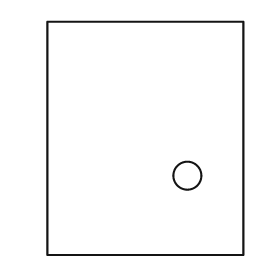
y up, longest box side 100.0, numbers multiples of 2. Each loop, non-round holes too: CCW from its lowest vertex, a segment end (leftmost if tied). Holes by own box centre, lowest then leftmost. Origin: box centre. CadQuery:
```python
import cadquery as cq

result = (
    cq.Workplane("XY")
    .moveTo(-42.0, -50.0)
    .lineTo(42.0, -50.0)
    .lineTo(42.0, 50.0)
    .lineTo(-42.0, 50.0)
    .close()
    .moveTo(18.0, -16.0)
    .circle(6.0)
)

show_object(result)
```